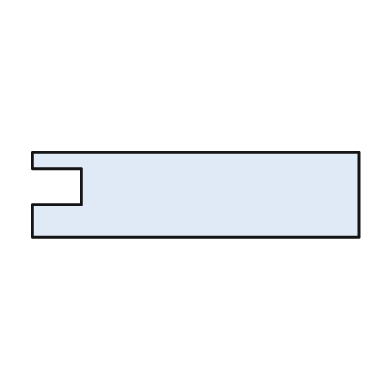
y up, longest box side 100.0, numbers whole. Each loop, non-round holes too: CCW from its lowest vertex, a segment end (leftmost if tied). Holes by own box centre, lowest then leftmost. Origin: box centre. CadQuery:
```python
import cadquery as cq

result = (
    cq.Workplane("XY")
    .moveTo(-50.0, -13.0)
    .lineTo(50.0, -13.0)
    .lineTo(50.0, 13.0)
    .lineTo(-50.0, 13.0)
    .lineTo(-50.0, 8.0)
    .lineTo(-35.0, 8.0)
    .lineTo(-35.0, -3.0)
    .lineTo(-50.0, -3.0)
    .close()
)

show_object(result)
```